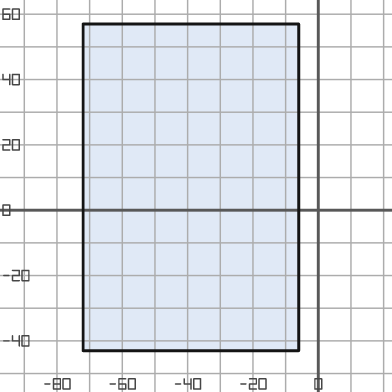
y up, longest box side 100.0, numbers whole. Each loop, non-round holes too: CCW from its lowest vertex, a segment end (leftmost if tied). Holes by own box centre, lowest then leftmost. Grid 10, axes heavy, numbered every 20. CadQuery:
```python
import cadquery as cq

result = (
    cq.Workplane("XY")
    .moveTo(-72.0, -43.0)
    .lineTo(-6.0, -43.0)
    .lineTo(-6.0, 57.0)
    .lineTo(-72.0, 57.0)
    .close()
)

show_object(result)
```